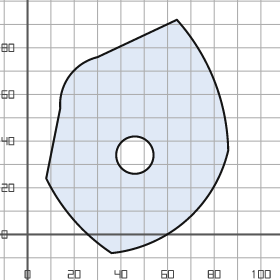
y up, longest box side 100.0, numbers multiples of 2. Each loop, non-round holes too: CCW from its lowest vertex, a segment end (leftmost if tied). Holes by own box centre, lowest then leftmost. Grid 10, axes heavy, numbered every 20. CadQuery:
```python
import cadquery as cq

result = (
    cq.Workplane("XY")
    .moveTo(36.0, -8.0)
    .threePointArc((68.0, 6.0), (86.0, 36.0))
    .threePointArc((80.0, 66.0), (64.0, 92.0))
    .lineTo(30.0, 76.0)
    .threePointArc((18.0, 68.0), (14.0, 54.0))
    .lineTo(8.0, 24.0)
    .threePointArc((20.0, 6.0), (36.0, -8.0))
    .close()
    .moveTo(46.0, 34.0)
    .circle(8.0)
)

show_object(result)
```